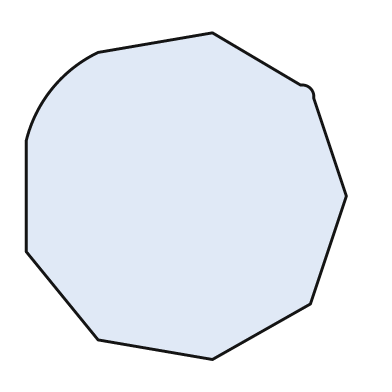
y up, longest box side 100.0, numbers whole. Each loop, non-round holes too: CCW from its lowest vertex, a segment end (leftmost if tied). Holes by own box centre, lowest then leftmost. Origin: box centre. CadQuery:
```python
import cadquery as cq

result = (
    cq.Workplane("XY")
    .moveTo(8.0, -50.0)
    .lineTo(38.0, -33.0)
    .lineTo(49.0, 0.0)
    .lineTo(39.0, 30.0)
    .threePointArc((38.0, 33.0), (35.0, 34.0))
    .lineTo(8.0, 50.0)
    .lineTo(-27.0, 44.0)
    .threePointArc((-41.0, 33.0), (-49.0, 17.0))
    .lineTo(-49.0, -17.0)
    .lineTo(-27.0, -44.0)
    .close()
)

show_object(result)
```